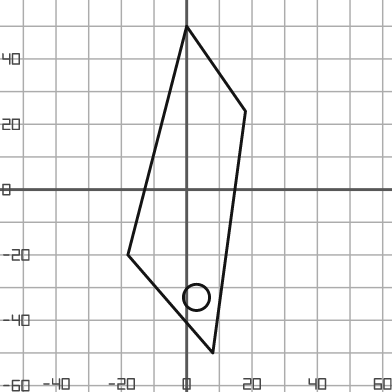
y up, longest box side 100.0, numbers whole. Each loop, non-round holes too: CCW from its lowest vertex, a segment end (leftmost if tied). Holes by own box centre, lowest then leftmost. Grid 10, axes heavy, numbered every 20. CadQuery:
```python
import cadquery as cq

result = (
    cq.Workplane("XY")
    .moveTo(8.0, -50.0)
    .lineTo(18.0, 24.0)
    .lineTo(0.0, 50.0)
    .lineTo(-18.0, -20.0)
    .close()
    .moveTo(3.0, -33.0)
    .circle(4.0)
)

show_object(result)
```